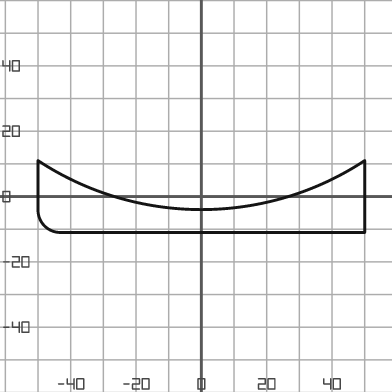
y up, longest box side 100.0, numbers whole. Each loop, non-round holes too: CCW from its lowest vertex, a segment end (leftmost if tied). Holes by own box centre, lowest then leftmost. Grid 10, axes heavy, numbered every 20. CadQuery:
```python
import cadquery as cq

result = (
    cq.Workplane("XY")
    .moveTo(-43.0, -11.0)
    .lineTo(50.0, -11.0)
    .lineTo(50.0, 11.0)
    .threePointArc((0.0, -4.0), (-50.0, 11.0))
    .lineTo(-50.0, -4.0)
    .threePointArc((-48.0, -9.0), (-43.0, -11.0))
    .close()
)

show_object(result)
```